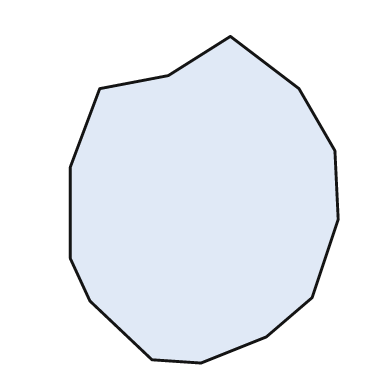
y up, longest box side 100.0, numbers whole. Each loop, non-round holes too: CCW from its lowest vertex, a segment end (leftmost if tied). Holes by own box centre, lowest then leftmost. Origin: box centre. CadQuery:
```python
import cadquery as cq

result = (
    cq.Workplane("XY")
    .moveTo(-1.0, -50.0)
    .lineTo(19.0, -42.0)
    .lineTo(33.0, -30.0)
    .lineTo(41.0, -6.0)
    .lineTo(40.0, 15.0)
    .lineTo(29.0, 34.0)
    .lineTo(8.0, 50.0)
    .lineTo(-11.0, 38.0)
    .lineTo(-32.0, 34.0)
    .lineTo(-41.0, 10.0)
    .lineTo(-41.0, -18.0)
    .lineTo(-35.0, -31.0)
    .lineTo(-16.0, -49.0)
    .close()
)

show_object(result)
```